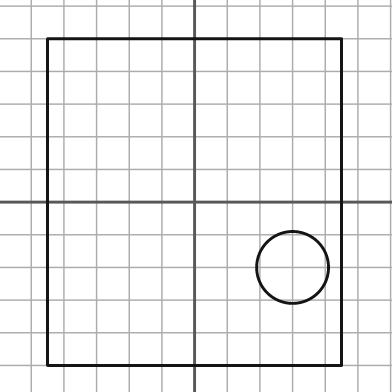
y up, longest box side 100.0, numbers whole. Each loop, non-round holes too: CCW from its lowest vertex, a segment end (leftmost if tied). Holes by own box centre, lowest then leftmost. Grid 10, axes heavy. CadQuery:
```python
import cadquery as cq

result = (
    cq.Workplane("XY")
    .moveTo(-45.0, -50.0)
    .lineTo(45.0, -50.0)
    .lineTo(45.0, 50.0)
    .lineTo(-45.0, 50.0)
    .close()
    .moveTo(30.0, -20.0)
    .circle(11.0)
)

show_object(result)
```